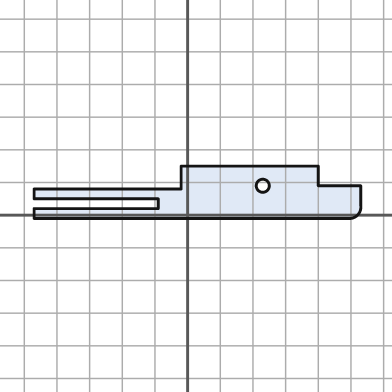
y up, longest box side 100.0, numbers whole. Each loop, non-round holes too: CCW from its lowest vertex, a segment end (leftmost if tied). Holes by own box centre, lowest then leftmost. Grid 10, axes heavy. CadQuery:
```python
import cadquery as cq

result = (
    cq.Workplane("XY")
    .moveTo(-47.0, -1.0)
    .lineTo(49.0, -1.0)
    .threePointArc((52.0, 0.0), (53.0, 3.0))
    .lineTo(53.0, 9.0)
    .lineTo(40.0, 9.0)
    .lineTo(40.0, 15.0)
    .lineTo(-2.0, 15.0)
    .lineTo(-2.0, 8.0)
    .lineTo(-47.0, 8.0)
    .lineTo(-47.0, 5.0)
    .lineTo(-9.0, 5.0)
    .lineTo(-9.0, 2.0)
    .lineTo(-47.0, 2.0)
    .close()
    .moveTo(23.0, 9.0)
    .circle(2.0)
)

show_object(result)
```